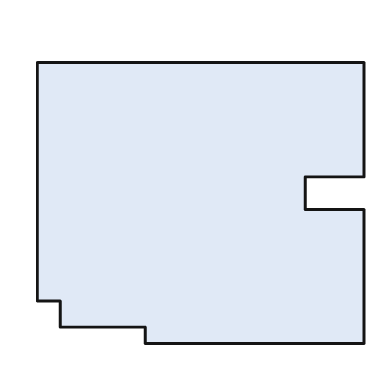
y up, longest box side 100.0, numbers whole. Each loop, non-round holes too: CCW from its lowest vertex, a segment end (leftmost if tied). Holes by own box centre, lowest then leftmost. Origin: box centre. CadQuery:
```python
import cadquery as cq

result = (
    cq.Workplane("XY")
    .moveTo(-17.0, -43.0)
    .lineTo(50.0, -43.0)
    .lineTo(50.0, -2.0)
    .lineTo(32.0, -2.0)
    .lineTo(32.0, 8.0)
    .lineTo(50.0, 8.0)
    .lineTo(50.0, 43.0)
    .lineTo(-50.0, 43.0)
    .lineTo(-50.0, -30.0)
    .lineTo(-43.0, -30.0)
    .lineTo(-43.0, -38.0)
    .lineTo(-17.0, -38.0)
    .close()
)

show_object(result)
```